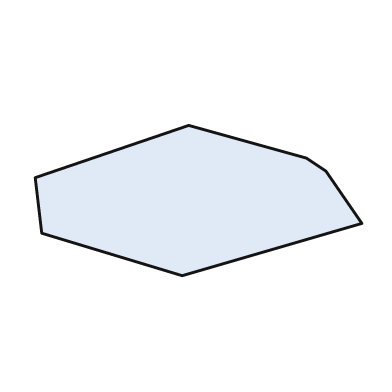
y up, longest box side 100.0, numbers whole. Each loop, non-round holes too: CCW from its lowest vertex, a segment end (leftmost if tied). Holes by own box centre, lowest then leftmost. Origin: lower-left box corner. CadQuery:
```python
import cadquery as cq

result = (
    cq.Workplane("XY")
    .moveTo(45.0, 0.0)
    .lineTo(100.0, 16.0)
    .lineTo(89.0, 32.0)
    .lineTo(83.0, 36.0)
    .lineTo(47.0, 46.0)
    .lineTo(0.0, 30.0)
    .lineTo(2.0, 13.0)
    .close()
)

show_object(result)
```